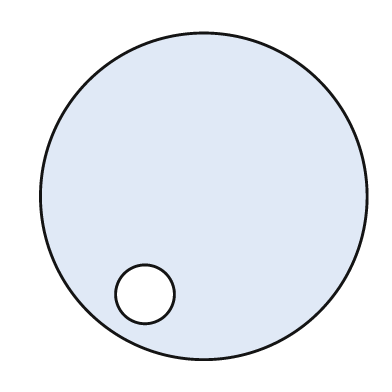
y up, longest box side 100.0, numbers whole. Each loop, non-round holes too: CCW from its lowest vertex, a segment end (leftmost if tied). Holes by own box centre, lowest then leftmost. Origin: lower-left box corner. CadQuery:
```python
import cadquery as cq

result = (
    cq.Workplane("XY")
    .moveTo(50.0, 50.0)
    .circle(50.0)
    .moveTo(32.0, 20.0)
    .circle(9.0)
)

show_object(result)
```